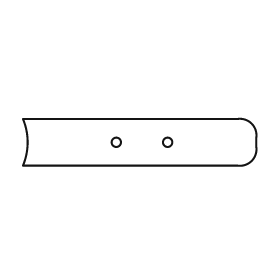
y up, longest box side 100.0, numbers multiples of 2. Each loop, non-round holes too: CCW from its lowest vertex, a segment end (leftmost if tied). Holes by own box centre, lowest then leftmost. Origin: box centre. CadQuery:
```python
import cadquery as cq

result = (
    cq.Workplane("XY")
    .moveTo(-50.0, -10.0)
    .lineTo(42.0, -10.0)
    .threePointArc((48.0, -8.0), (50.0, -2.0))
    .lineTo(50.0, 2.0)
    .threePointArc((48.0, 8.0), (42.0, 10.0))
    .lineTo(-50.0, 10.0)
    .threePointArc((-48.0, 0.0), (-50.0, -10.0))
    .close()
    .moveTo(-10.0, 0.0)
    .circle(2.0)
    .moveTo(12.0, 0.0)
    .circle(2.0)
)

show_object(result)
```